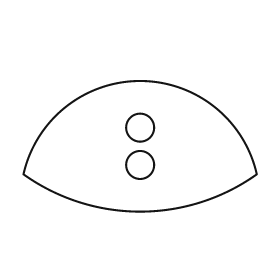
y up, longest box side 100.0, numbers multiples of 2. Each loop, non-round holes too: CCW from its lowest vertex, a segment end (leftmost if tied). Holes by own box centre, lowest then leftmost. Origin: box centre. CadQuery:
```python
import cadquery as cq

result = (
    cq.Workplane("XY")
    .moveTo(-50.0, -12.0)
    .threePointArc((0.0, -28.0), (50.0, -12.0))
    .threePointArc((0.0, 28.0), (-50.0, -12.0))
    .close()
    .moveTo(0.0, -8.0)
    .circle(6.0)
    .moveTo(0.0, 8.0)
    .circle(6.0)
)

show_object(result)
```